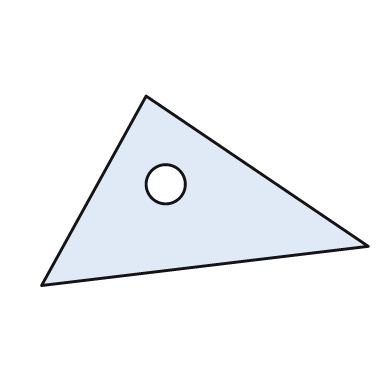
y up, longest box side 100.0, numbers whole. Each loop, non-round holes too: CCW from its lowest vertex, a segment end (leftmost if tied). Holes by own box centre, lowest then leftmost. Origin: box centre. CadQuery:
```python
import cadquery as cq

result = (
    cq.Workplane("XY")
    .moveTo(-50.0, -29.0)
    .lineTo(50.0, -17.0)
    .lineTo(-18.0, 29.0)
    .close()
    .moveTo(-12.0, 2.0)
    .circle(6.0)
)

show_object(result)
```